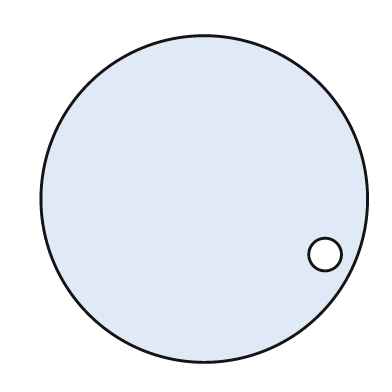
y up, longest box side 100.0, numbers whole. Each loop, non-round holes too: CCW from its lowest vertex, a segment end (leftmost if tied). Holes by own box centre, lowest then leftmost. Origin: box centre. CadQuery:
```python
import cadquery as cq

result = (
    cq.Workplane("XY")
    .moveTo(0.0, 0.0)
    .circle(50.0)
    .moveTo(37.0, -17.0)
    .circle(5.0)
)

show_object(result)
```